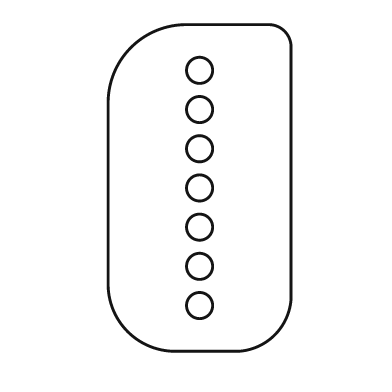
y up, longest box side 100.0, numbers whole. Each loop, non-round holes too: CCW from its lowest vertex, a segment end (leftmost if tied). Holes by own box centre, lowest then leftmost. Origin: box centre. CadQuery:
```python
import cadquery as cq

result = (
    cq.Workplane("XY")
    .moveTo(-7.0, -50.0)
    .lineTo(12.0, -50.0)
    .threePointArc((23.0, -45.0), (28.0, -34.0))
    .lineTo(28.0, 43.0)
    .threePointArc((26.0, 48.0), (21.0, 50.0))
    .lineTo(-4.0, 50.0)
    .threePointArc((-21.0, 43.0), (-28.0, 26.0))
    .lineTo(-28.0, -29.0)
    .threePointArc((-22.0, -44.0), (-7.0, -50.0))
    .close()
    .moveTo(0.0, -36.0)
    .circle(4.0)
    .moveTo(0.0, -24.0)
    .circle(4.0)
    .moveTo(0.0, -12.0)
    .circle(4.0)
    .moveTo(0.0, 0.0)
    .circle(4.0)
    .moveTo(0.0, 12.0)
    .circle(4.0)
    .moveTo(0.0, 24.0)
    .circle(4.0)
    .moveTo(0.0, 36.0)
    .circle(4.0)
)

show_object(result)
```